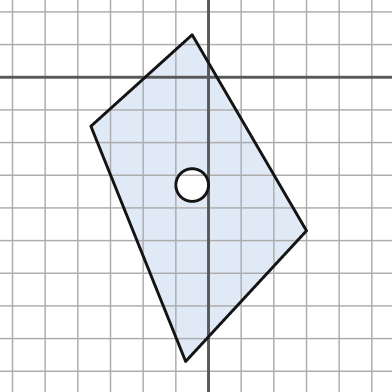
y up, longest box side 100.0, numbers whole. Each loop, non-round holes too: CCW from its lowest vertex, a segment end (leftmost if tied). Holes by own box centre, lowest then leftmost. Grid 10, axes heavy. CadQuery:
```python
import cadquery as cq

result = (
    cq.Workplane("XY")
    .moveTo(-7.0, -87.0)
    .lineTo(30.0, -47.0)
    .lineTo(-5.0, 13.0)
    .lineTo(-36.0, -15.0)
    .close()
    .moveTo(-5.0, -33.0)
    .circle(5.0)
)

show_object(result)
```